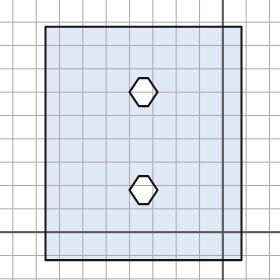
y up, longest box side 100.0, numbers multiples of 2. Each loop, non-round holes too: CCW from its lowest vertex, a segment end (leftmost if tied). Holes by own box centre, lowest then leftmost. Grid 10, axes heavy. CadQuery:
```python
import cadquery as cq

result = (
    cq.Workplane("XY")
    .moveTo(-76.0, -12.0)
    .lineTo(8.0, -12.0)
    .lineTo(8.0, 88.0)
    .lineTo(-76.0, 88.0)
    .close()
    .moveTo(-36.0, 12.0)
    .lineTo(-32.0, 12.0)
    .lineTo(-28.0, 18.0)
    .lineTo(-32.0, 24.0)
    .lineTo(-36.0, 24.0)
    .lineTo(-40.0, 18.0)
    .close()
    .moveTo(-36.0, 54.0)
    .lineTo(-32.0, 54.0)
    .lineTo(-28.0, 60.0)
    .lineTo(-32.0, 66.0)
    .lineTo(-36.0, 66.0)
    .lineTo(-40.0, 60.0)
    .close()
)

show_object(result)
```